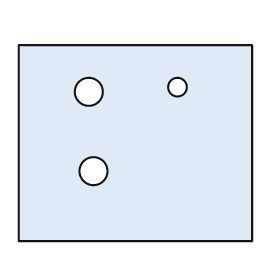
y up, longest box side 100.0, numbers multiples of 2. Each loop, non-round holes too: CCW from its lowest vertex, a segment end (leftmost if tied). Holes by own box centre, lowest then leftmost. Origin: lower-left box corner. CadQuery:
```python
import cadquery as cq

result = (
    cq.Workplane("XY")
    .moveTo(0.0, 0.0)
    .lineTo(100.0, 0.0)
    .lineTo(100.0, 84.0)
    .lineTo(0.0, 84.0)
    .close()
    .moveTo(32.0, 30.0)
    .circle(6.0)
    .moveTo(30.0, 64.0)
    .circle(6.0)
    .moveTo(68.0, 66.0)
    .circle(4.0)
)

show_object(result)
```